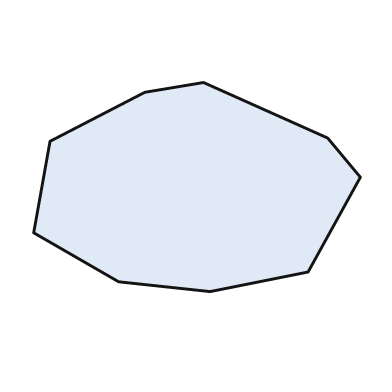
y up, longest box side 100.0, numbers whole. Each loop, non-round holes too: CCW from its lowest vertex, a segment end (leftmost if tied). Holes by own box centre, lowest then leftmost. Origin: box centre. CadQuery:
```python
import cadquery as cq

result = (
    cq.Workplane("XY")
    .moveTo(4.0, -32.0)
    .lineTo(34.0, -26.0)
    .lineTo(50.0, 3.0)
    .lineTo(40.0, 15.0)
    .lineTo(2.0, 32.0)
    .lineTo(-16.0, 29.0)
    .lineTo(-45.0, 14.0)
    .lineTo(-50.0, -14.0)
    .lineTo(-24.0, -29.0)
    .close()
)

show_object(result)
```